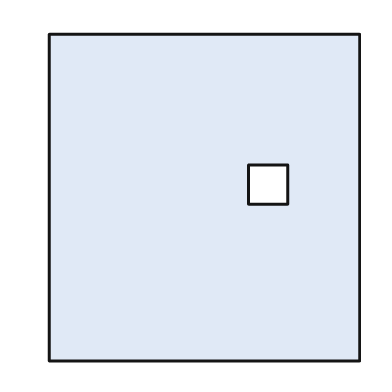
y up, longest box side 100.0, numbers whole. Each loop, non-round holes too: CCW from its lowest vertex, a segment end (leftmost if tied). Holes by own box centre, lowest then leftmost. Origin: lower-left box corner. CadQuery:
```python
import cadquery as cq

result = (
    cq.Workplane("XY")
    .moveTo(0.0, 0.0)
    .lineTo(95.0, 0.0)
    .lineTo(95.0, 100.0)
    .lineTo(0.0, 100.0)
    .close()
    .moveTo(61.0, 48.0)
    .lineTo(73.0, 48.0)
    .lineTo(73.0, 60.0)
    .lineTo(61.0, 60.0)
    .close()
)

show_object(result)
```